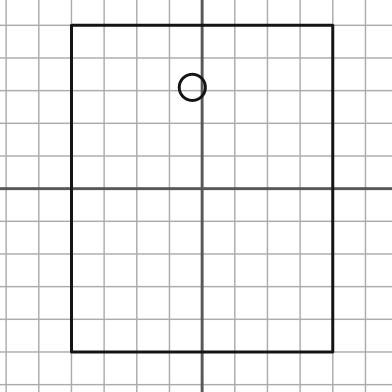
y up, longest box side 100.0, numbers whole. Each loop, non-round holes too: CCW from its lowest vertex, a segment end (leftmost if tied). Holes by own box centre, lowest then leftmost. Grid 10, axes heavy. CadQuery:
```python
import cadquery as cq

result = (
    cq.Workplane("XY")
    .moveTo(-40.0, -50.0)
    .lineTo(40.0, -50.0)
    .lineTo(40.0, 50.0)
    .lineTo(-40.0, 50.0)
    .close()
    .moveTo(-3.0, 31.0)
    .circle(4.0)
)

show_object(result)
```